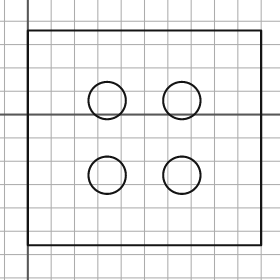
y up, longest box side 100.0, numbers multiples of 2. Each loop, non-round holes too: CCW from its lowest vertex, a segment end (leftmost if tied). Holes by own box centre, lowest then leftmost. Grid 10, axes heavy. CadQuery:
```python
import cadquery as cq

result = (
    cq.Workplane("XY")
    .moveTo(0.0, -56.0)
    .lineTo(100.0, -56.0)
    .lineTo(100.0, 36.0)
    .lineTo(0.0, 36.0)
    .close()
    .moveTo(34.0, -26.0)
    .circle(8.0)
    .moveTo(66.0, -26.0)
    .circle(8.0)
    .moveTo(34.0, 6.0)
    .circle(8.0)
    .moveTo(66.0, 6.0)
    .circle(8.0)
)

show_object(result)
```